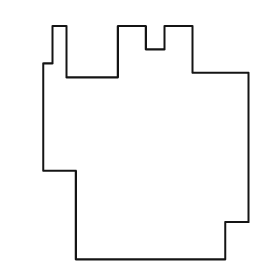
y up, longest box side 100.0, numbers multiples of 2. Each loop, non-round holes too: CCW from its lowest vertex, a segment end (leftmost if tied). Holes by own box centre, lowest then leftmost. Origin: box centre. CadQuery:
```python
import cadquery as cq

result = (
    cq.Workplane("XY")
    .moveTo(-30.0, -50.0)
    .lineTo(34.0, -50.0)
    .lineTo(34.0, -34.0)
    .lineTo(44.0, -34.0)
    .lineTo(44.0, 30.0)
    .lineTo(20.0, 30.0)
    .lineTo(20.0, 50.0)
    .lineTo(8.0, 50.0)
    .lineTo(8.0, 40.0)
    .lineTo(0.0, 40.0)
    .lineTo(0.0, 50.0)
    .lineTo(-12.0, 50.0)
    .lineTo(-12.0, 28.0)
    .lineTo(-34.0, 28.0)
    .lineTo(-34.0, 50.0)
    .lineTo(-40.0, 50.0)
    .lineTo(-40.0, 34.0)
    .lineTo(-44.0, 34.0)
    .lineTo(-44.0, -12.0)
    .lineTo(-30.0, -12.0)
    .close()
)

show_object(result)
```